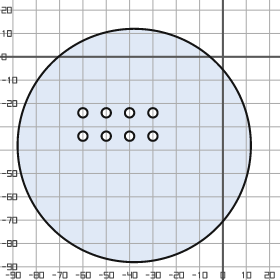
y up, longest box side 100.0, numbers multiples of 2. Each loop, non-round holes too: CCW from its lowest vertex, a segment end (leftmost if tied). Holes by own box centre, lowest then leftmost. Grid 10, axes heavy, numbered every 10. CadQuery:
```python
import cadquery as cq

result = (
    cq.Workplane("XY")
    .moveTo(-38.0, -38.0)
    .circle(50.0)
    .moveTo(-60.0, -34.0)
    .circle(2.0)
    .moveTo(-50.0, -34.0)
    .circle(2.0)
    .moveTo(-40.0, -34.0)
    .circle(2.0)
    .moveTo(-30.0, -34.0)
    .circle(2.0)
    .moveTo(-60.0, -24.0)
    .circle(2.0)
    .moveTo(-50.0, -24.0)
    .circle(2.0)
    .moveTo(-40.0, -24.0)
    .circle(2.0)
    .moveTo(-30.0, -24.0)
    .circle(2.0)
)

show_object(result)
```